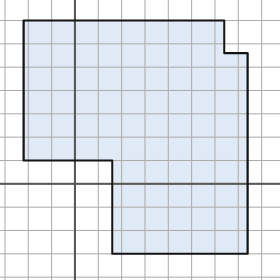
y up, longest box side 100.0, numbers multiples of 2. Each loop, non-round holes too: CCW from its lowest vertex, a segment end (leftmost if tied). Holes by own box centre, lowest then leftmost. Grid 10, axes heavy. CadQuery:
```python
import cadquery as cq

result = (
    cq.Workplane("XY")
    .moveTo(16.0, -30.0)
    .lineTo(74.0, -30.0)
    .lineTo(74.0, 56.0)
    .lineTo(64.0, 56.0)
    .lineTo(64.0, 70.0)
    .lineTo(-22.0, 70.0)
    .lineTo(-22.0, 10.0)
    .lineTo(16.0, 10.0)
    .close()
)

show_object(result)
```